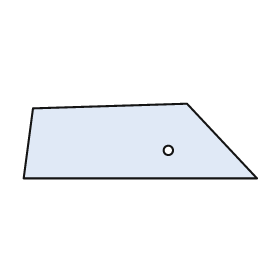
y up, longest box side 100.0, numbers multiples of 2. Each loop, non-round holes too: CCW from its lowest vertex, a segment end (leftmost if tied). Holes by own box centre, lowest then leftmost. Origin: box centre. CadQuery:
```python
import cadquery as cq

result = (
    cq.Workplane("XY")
    .moveTo(-50.0, -16.0)
    .lineTo(50.0, -16.0)
    .lineTo(20.0, 16.0)
    .lineTo(-46.0, 14.0)
    .close()
    .moveTo(12.0, -4.0)
    .circle(2.0)
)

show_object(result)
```